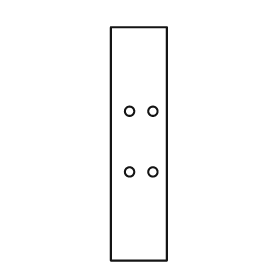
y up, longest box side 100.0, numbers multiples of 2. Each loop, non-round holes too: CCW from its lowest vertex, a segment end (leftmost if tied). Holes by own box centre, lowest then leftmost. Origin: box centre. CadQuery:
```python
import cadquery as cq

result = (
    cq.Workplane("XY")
    .moveTo(-12.0, -50.0)
    .lineTo(12.0, -50.0)
    .lineTo(12.0, 50.0)
    .lineTo(-12.0, 50.0)
    .close()
    .moveTo(-4.0, -12.0)
    .circle(2.0)
    .moveTo(6.0, -12.0)
    .circle(2.0)
    .moveTo(-4.0, 14.0)
    .circle(2.0)
    .moveTo(6.0, 14.0)
    .circle(2.0)
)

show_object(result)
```